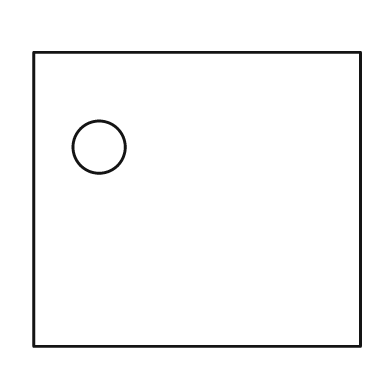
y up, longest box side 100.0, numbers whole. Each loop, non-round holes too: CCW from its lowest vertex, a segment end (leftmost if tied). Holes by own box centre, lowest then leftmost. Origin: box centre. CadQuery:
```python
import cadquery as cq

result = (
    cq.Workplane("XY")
    .moveTo(-50.0, -45.0)
    .lineTo(50.0, -45.0)
    .lineTo(50.0, 45.0)
    .lineTo(-50.0, 45.0)
    .close()
    .moveTo(-30.0, 16.0)
    .circle(8.0)
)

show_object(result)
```